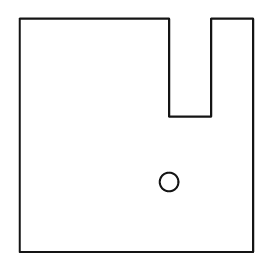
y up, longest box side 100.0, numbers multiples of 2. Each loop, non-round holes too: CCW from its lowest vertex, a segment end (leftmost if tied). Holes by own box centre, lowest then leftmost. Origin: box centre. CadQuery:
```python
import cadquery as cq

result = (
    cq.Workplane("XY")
    .moveTo(-50.0, -50.0)
    .lineTo(50.0, -50.0)
    .lineTo(50.0, 50.0)
    .lineTo(32.0, 50.0)
    .lineTo(32.0, 8.0)
    .lineTo(14.0, 8.0)
    .lineTo(14.0, 50.0)
    .lineTo(-50.0, 50.0)
    .close()
    .moveTo(14.0, -20.0)
    .circle(4.0)
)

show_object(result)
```